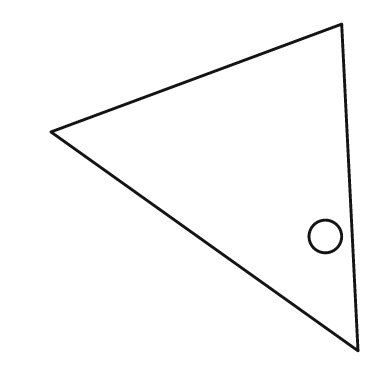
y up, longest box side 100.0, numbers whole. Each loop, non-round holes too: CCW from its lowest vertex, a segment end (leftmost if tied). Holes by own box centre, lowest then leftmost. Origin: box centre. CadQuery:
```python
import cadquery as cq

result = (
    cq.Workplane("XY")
    .moveTo(47.0, -50.0)
    .lineTo(42.0, 50.0)
    .lineTo(-47.0, 17.0)
    .close()
    .moveTo(37.0, -15.0)
    .circle(5.0)
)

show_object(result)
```